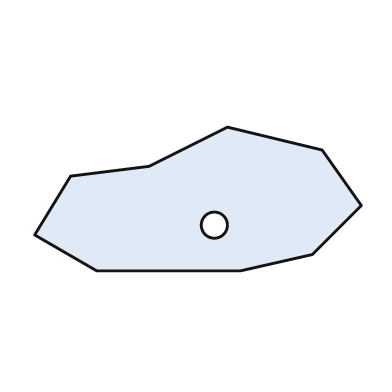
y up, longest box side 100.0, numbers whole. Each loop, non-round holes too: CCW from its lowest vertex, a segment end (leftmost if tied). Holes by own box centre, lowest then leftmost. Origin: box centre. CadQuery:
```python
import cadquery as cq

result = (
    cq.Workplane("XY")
    .moveTo(-31.0, -22.0)
    .lineTo(13.0, -22.0)
    .lineTo(35.0, -17.0)
    .lineTo(50.0, -2.0)
    .lineTo(38.0, 15.0)
    .lineTo(9.0, 22.0)
    .lineTo(-15.0, 10.0)
    .lineTo(-39.0, 7.0)
    .lineTo(-50.0, -11.0)
    .close()
    .moveTo(5.0, -8.0)
    .circle(4.0)
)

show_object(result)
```